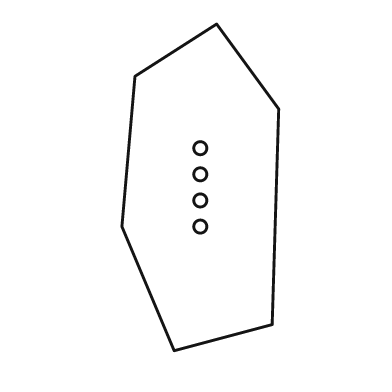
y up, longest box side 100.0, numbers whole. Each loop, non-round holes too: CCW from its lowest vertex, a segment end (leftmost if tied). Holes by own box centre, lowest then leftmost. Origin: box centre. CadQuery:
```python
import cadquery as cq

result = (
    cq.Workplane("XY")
    .moveTo(-8.0, -50.0)
    .lineTo(22.0, -42.0)
    .lineTo(24.0, 24.0)
    .lineTo(5.0, 50.0)
    .lineTo(-20.0, 34.0)
    .lineTo(-24.0, -12.0)
    .close()
    .moveTo(0.0, -12.0)
    .circle(2.0)
    .moveTo(0.0, -4.0)
    .circle(2.0)
    .moveTo(0.0, 4.0)
    .circle(2.0)
    .moveTo(0.0, 12.0)
    .circle(2.0)
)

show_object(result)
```